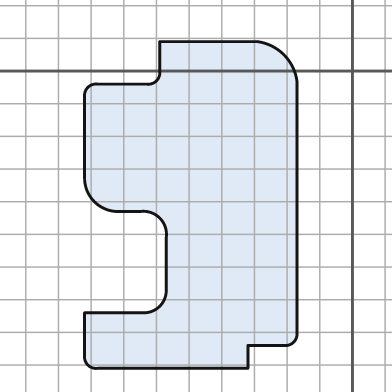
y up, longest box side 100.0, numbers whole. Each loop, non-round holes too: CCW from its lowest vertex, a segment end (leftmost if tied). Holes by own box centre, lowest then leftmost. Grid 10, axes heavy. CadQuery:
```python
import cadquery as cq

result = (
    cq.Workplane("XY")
    .moveTo(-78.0, -91.0)
    .lineTo(-32.0, -91.0)
    .lineTo(-32.0, -84.0)
    .lineTo(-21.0, -84.0)
    .threePointArc((-18.0, -83.0), (-17.0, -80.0))
    .lineTo(-17.0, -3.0)
    .threePointArc((-21.0, 5.0), (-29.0, 9.0))
    .lineTo(-59.0, 9.0)
    .lineTo(-59.0, 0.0)
    .threePointArc((-60.0, -3.0), (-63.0, -4.0))
    .lineTo(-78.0, -4.0)
    .threePointArc((-81.0, -5.0), (-82.0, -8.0))
    .lineTo(-82.0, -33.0)
    .threePointArc((-79.0, -40.0), (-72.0, -43.0))
    .lineTo(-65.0, -43.0)
    .threePointArc((-59.0, -45.0), (-57.0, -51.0))
    .lineTo(-57.0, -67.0)
    .threePointArc((-59.0, -72.0), (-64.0, -74.0))
    .lineTo(-82.0, -74.0)
    .lineTo(-82.0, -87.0)
    .threePointArc((-81.0, -90.0), (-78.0, -91.0))
    .close()
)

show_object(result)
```